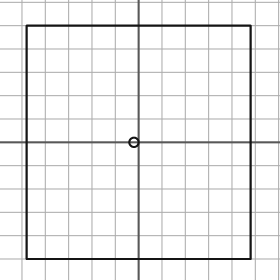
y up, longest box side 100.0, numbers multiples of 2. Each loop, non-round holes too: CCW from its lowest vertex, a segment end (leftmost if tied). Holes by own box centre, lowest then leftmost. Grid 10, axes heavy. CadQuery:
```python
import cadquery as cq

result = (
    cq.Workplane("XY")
    .moveTo(-48.0, -50.0)
    .lineTo(48.0, -50.0)
    .lineTo(48.0, 50.0)
    .lineTo(-48.0, 50.0)
    .close()
    .moveTo(-2.0, 0.0)
    .circle(2.0)
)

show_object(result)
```